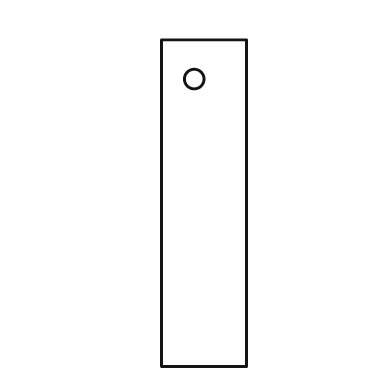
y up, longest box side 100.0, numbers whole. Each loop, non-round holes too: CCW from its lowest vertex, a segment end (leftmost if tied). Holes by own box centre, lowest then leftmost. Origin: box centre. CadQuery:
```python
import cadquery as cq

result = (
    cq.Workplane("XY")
    .moveTo(-13.0, -50.0)
    .lineTo(13.0, -50.0)
    .lineTo(13.0, 50.0)
    .lineTo(-13.0, 50.0)
    .close()
    .moveTo(-3.0, 38.0)
    .circle(3.0)
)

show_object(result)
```